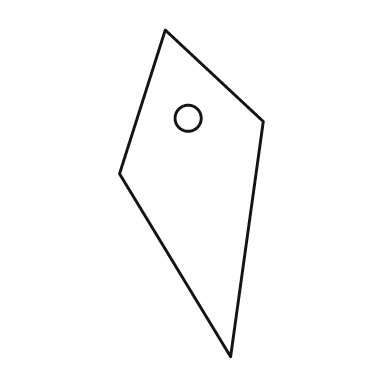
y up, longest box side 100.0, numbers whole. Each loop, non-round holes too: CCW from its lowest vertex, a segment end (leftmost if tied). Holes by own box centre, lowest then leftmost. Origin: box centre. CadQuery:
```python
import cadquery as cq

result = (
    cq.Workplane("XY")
    .moveTo(12.0, -50.0)
    .lineTo(22.0, 22.0)
    .lineTo(-8.0, 50.0)
    .lineTo(-22.0, 6.0)
    .close()
    .moveTo(-1.0, 23.0)
    .circle(4.0)
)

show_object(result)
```